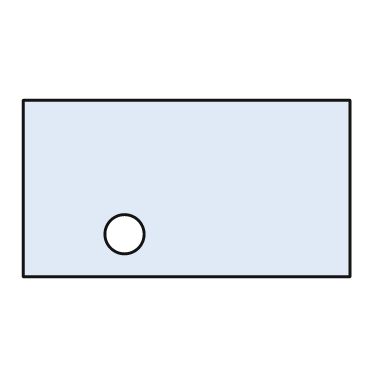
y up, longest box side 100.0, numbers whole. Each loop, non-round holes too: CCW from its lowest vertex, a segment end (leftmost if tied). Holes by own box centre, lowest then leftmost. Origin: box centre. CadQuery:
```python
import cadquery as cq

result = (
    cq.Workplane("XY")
    .moveTo(-50.0, -27.0)
    .lineTo(50.0, -27.0)
    .lineTo(50.0, 27.0)
    .lineTo(-50.0, 27.0)
    .close()
    .moveTo(-19.0, -14.0)
    .circle(6.0)
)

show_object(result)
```